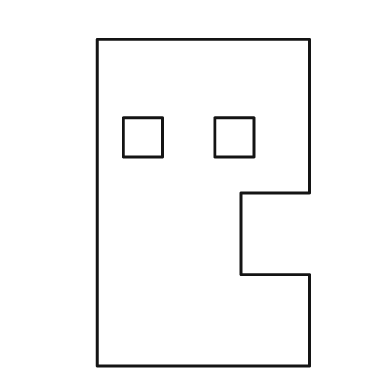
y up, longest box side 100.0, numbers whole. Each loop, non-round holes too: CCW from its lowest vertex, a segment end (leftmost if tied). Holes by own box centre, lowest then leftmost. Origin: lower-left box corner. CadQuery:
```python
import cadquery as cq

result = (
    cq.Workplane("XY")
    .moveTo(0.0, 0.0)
    .lineTo(65.0, 0.0)
    .lineTo(65.0, 28.0)
    .lineTo(44.0, 28.0)
    .lineTo(44.0, 53.0)
    .lineTo(65.0, 53.0)
    .lineTo(65.0, 100.0)
    .lineTo(0.0, 100.0)
    .close()
    .moveTo(8.0, 64.0)
    .lineTo(20.0, 64.0)
    .lineTo(20.0, 76.0)
    .lineTo(8.0, 76.0)
    .close()
    .moveTo(36.0, 64.0)
    .lineTo(48.0, 64.0)
    .lineTo(48.0, 76.0)
    .lineTo(36.0, 76.0)
    .close()
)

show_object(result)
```